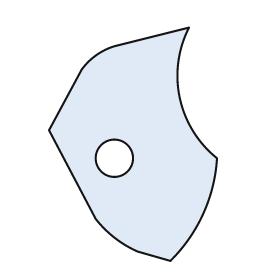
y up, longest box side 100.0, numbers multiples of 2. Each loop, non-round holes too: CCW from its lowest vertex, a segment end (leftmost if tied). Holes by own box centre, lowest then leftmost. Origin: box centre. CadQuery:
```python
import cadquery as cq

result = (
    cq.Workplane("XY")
    .moveTo(16.0, -50.0)
    .threePointArc((30.0, -30.0), (36.0, -6.0))
    .threePointArc((20.0, 20.0), (24.0, 50.0))
    .lineTo(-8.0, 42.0)
    .threePointArc((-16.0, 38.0), (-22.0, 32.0))
    .lineTo(-36.0, 6.0)
    .lineTo(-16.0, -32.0)
    .threePointArc((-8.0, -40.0), (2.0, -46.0))
    .close()
    .moveTo(-8.0, -6.0)
    .circle(8.0)
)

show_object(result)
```